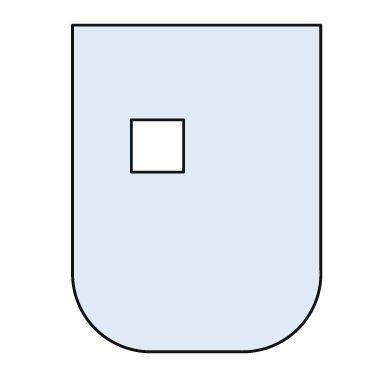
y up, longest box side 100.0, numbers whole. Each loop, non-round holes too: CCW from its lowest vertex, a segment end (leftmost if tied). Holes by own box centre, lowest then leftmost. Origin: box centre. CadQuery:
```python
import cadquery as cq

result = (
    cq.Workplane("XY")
    .moveTo(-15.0, -50.0)
    .lineTo(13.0, -50.0)
    .threePointArc((31.0, -43.0), (38.0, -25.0))
    .lineTo(38.0, 50.0)
    .lineTo(-38.0, 50.0)
    .lineTo(-38.0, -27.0)
    .threePointArc((-31.0, -43.0), (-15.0, -50.0))
    .close()
    .moveTo(-20.0, 5.0)
    .lineTo(-4.0, 5.0)
    .lineTo(-4.0, 21.0)
    .lineTo(-20.0, 21.0)
    .close()
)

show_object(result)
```